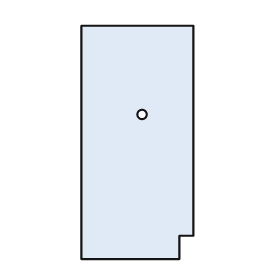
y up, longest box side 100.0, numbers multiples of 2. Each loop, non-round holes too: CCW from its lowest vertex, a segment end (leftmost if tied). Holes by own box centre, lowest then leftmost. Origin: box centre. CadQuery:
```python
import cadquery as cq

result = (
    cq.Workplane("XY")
    .moveTo(-24.0, -50.0)
    .lineTo(18.0, -50.0)
    .lineTo(18.0, -40.0)
    .lineTo(24.0, -40.0)
    .lineTo(24.0, 50.0)
    .lineTo(-24.0, 50.0)
    .close()
    .moveTo(2.0, 12.0)
    .circle(2.0)
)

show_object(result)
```